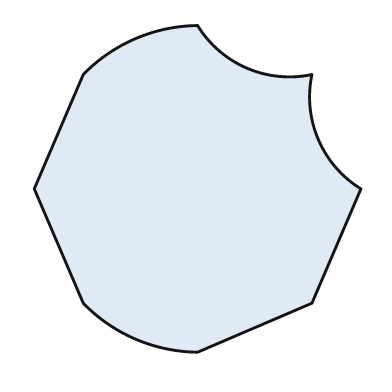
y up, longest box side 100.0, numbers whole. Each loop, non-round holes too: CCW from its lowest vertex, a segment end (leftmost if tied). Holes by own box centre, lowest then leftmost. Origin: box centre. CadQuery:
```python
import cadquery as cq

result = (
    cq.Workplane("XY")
    .moveTo(0.0, -50.0)
    .lineTo(35.0, -35.0)
    .lineTo(50.0, 0.0)
    .threePointArc((37.0, 15.0), (35.0, 35.0))
    .threePointArc((15.0, 37.0), (0.0, 50.0))
    .threePointArc((-19.0, 46.0), (-35.0, 35.0))
    .lineTo(-50.0, 0.0)
    .lineTo(-35.0, -35.0)
    .threePointArc((-19.0, -46.0), (0.0, -50.0))
    .close()
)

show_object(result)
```